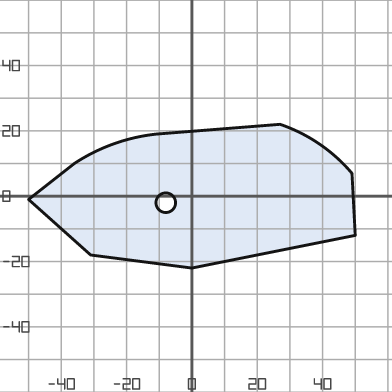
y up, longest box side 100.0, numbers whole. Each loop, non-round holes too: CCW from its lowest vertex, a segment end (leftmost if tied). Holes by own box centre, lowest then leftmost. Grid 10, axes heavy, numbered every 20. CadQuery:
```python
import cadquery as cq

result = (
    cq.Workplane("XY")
    .moveTo(0.0, -22.0)
    .lineTo(50.0, -12.0)
    .lineTo(49.0, 7.0)
    .threePointArc((39.0, 16.0), (27.0, 22.0))
    .lineTo(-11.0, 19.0)
    .threePointArc((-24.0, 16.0), (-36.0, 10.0))
    .lineTo(-50.0, -1.0)
    .lineTo(-31.0, -18.0)
    .close()
    .moveTo(-8.0, -2.0)
    .circle(3.0)
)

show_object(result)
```